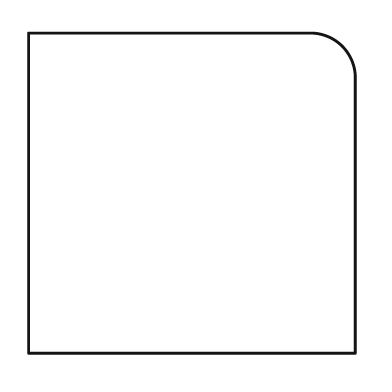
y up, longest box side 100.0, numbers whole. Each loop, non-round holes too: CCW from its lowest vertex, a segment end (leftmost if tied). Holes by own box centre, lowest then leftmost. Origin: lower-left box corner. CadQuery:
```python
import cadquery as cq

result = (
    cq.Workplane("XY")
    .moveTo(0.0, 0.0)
    .lineTo(100.0, 0.0)
    .lineTo(100.0, 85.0)
    .threePointArc((96.0, 94.0), (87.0, 98.0))
    .lineTo(0.0, 98.0)
    .close()
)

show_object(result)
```